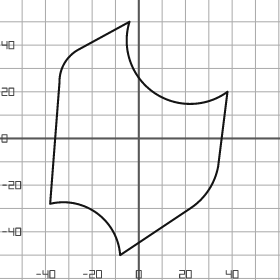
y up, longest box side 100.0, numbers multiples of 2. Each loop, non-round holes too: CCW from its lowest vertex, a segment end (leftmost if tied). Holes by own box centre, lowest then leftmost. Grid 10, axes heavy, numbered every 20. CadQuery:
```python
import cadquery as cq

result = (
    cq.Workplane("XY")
    .moveTo(-8.0, -50.0)
    .lineTo(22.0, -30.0)
    .threePointArc((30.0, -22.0), (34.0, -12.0))
    .lineTo(38.0, 20.0)
    .threePointArc((6.0, 20.0), (-4.0, 50.0))
    .lineTo(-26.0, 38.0)
    .threePointArc((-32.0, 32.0), (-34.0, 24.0))
    .lineTo(-38.0, -28.0)
    .threePointArc((-18.0, -32.0), (-8.0, -50.0))
    .close()
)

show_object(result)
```